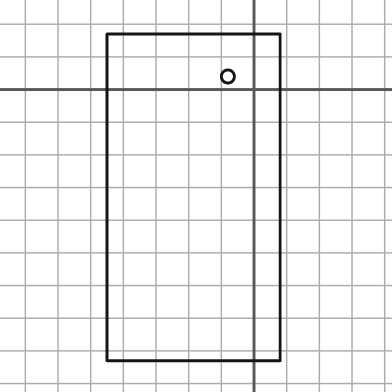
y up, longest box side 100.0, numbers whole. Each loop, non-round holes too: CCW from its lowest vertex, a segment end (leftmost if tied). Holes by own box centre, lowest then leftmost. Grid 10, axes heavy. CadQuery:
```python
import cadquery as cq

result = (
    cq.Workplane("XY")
    .moveTo(-45.0, -83.0)
    .lineTo(8.0, -83.0)
    .lineTo(8.0, 17.0)
    .lineTo(-45.0, 17.0)
    .close()
    .moveTo(-8.0, 4.0)
    .circle(2.0)
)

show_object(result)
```